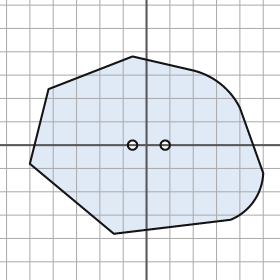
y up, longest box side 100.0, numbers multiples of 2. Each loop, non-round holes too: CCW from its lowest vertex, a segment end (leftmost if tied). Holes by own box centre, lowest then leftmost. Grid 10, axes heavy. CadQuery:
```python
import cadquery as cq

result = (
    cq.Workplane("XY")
    .moveTo(-14.0, -38.0)
    .lineTo(36.0, -32.0)
    .threePointArc((46.0, -24.0), (50.0, -12.0))
    .lineTo(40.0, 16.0)
    .threePointArc((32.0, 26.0), (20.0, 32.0))
    .lineTo(-6.0, 38.0)
    .lineTo(-42.0, 24.0)
    .lineTo(-50.0, -8.0)
    .close()
    .moveTo(-6.0, 0.0)
    .circle(2.0)
    .moveTo(8.0, 0.0)
    .circle(2.0)
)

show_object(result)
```